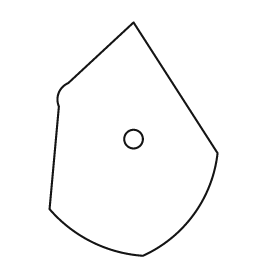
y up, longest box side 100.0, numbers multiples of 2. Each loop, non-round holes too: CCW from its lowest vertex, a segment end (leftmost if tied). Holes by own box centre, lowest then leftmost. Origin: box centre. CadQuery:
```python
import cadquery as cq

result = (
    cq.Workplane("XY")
    .moveTo(4.0, -50.0)
    .threePointArc((26.0, -32.0), (36.0, -6.0))
    .lineTo(0.0, 50.0)
    .lineTo(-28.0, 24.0)
    .threePointArc((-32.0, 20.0), (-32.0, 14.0))
    .lineTo(-36.0, -30.0)
    .threePointArc((-18.0, -44.0), (4.0, -50.0))
    .close()
    .moveTo(0.0, 0.0)
    .circle(4.0)
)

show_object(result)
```